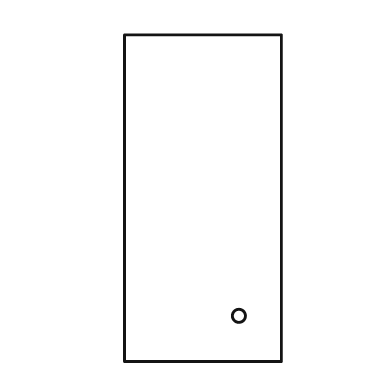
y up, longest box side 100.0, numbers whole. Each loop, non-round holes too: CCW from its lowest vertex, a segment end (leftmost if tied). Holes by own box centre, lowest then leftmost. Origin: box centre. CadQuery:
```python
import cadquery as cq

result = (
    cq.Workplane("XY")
    .moveTo(-24.0, -50.0)
    .lineTo(24.0, -50.0)
    .lineTo(24.0, 50.0)
    .lineTo(-24.0, 50.0)
    .close()
    .moveTo(11.0, -36.0)
    .circle(2.0)
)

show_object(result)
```